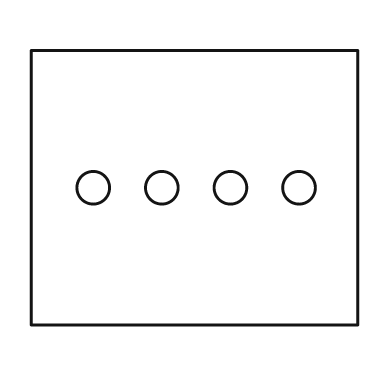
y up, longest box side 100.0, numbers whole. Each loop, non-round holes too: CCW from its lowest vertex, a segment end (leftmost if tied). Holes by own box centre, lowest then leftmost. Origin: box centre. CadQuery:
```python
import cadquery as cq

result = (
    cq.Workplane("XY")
    .moveTo(-50.0, -42.0)
    .lineTo(50.0, -42.0)
    .lineTo(50.0, 42.0)
    .lineTo(-50.0, 42.0)
    .close()
    .moveTo(-31.0, 0.0)
    .circle(5.0)
    .moveTo(-10.0, 0.0)
    .circle(5.0)
    .moveTo(11.0, 0.0)
    .circle(5.0)
    .moveTo(32.0, 0.0)
    .circle(5.0)
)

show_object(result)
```